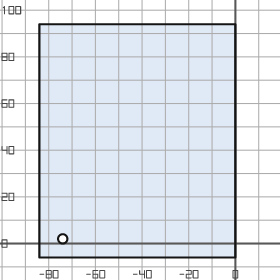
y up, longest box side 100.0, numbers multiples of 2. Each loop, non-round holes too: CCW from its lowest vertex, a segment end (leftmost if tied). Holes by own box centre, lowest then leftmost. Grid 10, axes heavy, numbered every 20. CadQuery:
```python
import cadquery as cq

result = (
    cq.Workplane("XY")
    .moveTo(-84.0, -6.0)
    .lineTo(0.0, -6.0)
    .lineTo(0.0, 94.0)
    .lineTo(-84.0, 94.0)
    .close()
    .moveTo(-74.0, 2.0)
    .circle(2.0)
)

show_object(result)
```